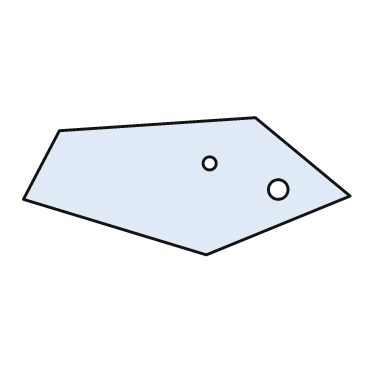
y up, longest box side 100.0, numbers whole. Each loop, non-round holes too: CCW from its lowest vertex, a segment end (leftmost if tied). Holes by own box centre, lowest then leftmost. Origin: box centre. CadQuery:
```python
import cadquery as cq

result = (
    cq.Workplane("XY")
    .moveTo(6.0, -21.0)
    .lineTo(50.0, -3.0)
    .lineTo(21.0, 21.0)
    .lineTo(-39.0, 17.0)
    .lineTo(-50.0, -4.0)
    .close()
    .moveTo(28.0, -1.0)
    .circle(3.0)
    .moveTo(7.0, 7.0)
    .circle(2.0)
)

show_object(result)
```